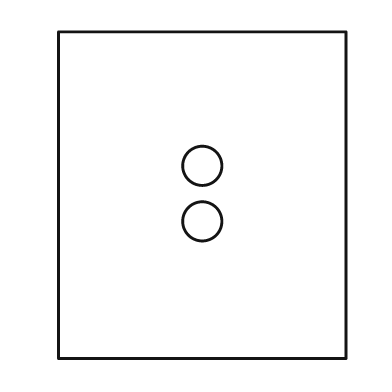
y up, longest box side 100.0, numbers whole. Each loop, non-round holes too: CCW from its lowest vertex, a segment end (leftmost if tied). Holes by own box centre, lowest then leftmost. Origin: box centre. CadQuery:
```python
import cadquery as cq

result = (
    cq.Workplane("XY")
    .moveTo(-44.0, -50.0)
    .lineTo(44.0, -50.0)
    .lineTo(44.0, 50.0)
    .lineTo(-44.0, 50.0)
    .close()
    .moveTo(0.0, -8.0)
    .circle(6.0)
    .moveTo(0.0, 9.0)
    .circle(6.0)
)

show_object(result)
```